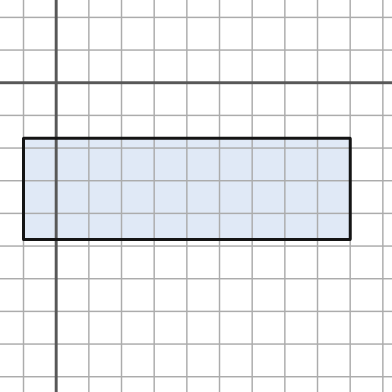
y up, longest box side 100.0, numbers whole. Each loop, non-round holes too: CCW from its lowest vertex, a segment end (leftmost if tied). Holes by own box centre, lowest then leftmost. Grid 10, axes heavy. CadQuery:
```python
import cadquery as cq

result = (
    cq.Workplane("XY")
    .moveTo(-10.0, -48.0)
    .lineTo(90.0, -48.0)
    .lineTo(90.0, -17.0)
    .lineTo(-10.0, -17.0)
    .close()
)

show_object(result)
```